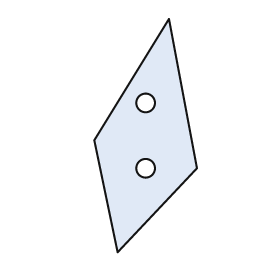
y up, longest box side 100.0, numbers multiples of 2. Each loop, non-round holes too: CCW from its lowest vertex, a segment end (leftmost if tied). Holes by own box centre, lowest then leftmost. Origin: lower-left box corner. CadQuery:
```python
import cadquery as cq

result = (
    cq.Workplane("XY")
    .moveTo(10.0, 0.0)
    .lineTo(44.0, 36.0)
    .lineTo(32.0, 100.0)
    .lineTo(0.0, 48.0)
    .close()
    .moveTo(22.0, 36.0)
    .circle(4.0)
    .moveTo(22.0, 64.0)
    .circle(4.0)
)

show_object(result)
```